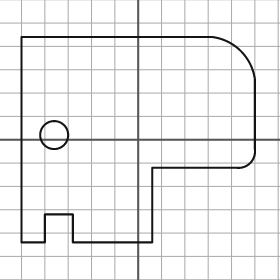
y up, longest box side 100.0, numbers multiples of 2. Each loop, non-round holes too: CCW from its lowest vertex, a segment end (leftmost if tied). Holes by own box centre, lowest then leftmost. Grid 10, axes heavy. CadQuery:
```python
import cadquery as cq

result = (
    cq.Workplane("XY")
    .moveTo(-50.0, -44.0)
    .lineTo(-40.0, -44.0)
    .lineTo(-40.0, -32.0)
    .lineTo(-28.0, -32.0)
    .lineTo(-28.0, -44.0)
    .lineTo(6.0, -44.0)
    .lineTo(6.0, -12.0)
    .lineTo(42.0, -12.0)
    .threePointArc((48.0, -10.0), (50.0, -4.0))
    .lineTo(50.0, 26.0)
    .threePointArc((44.0, 38.0), (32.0, 44.0))
    .lineTo(-50.0, 44.0)
    .close()
    .moveTo(-36.0, 2.0)
    .circle(6.0)
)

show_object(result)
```